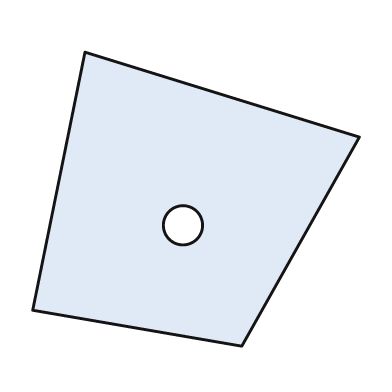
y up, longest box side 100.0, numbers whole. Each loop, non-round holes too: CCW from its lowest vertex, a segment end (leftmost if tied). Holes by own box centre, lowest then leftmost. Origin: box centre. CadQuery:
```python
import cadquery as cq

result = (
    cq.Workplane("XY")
    .moveTo(14.0, -45.0)
    .lineTo(50.0, 19.0)
    .lineTo(-34.0, 45.0)
    .lineTo(-50.0, -34.0)
    .close()
    .moveTo(-4.0, -8.0)
    .circle(6.0)
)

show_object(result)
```